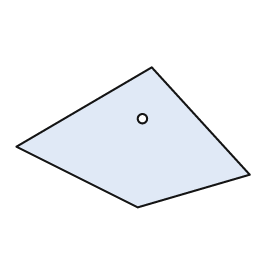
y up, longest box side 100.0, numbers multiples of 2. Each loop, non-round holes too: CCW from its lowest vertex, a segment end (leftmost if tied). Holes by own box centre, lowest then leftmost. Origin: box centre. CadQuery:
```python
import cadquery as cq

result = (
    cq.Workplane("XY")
    .moveTo(2.0, -30.0)
    .lineTo(50.0, -16.0)
    .lineTo(8.0, 30.0)
    .lineTo(-50.0, -4.0)
    .close()
    .moveTo(4.0, 8.0)
    .circle(2.0)
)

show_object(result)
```